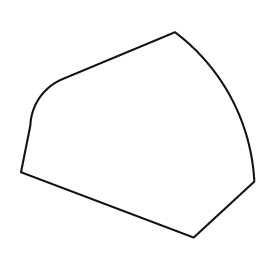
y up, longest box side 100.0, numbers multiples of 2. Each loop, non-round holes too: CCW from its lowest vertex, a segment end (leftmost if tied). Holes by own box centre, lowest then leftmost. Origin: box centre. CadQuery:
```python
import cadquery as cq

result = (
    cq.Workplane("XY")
    .moveTo(24.0, -44.0)
    .lineTo(50.0, -20.0)
    .threePointArc((40.0, 16.0), (16.0, 44.0))
    .lineTo(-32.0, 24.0)
    .threePointArc((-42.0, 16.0), (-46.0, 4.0))
    .lineTo(-50.0, -16.0)
    .close()
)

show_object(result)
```